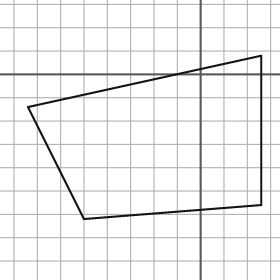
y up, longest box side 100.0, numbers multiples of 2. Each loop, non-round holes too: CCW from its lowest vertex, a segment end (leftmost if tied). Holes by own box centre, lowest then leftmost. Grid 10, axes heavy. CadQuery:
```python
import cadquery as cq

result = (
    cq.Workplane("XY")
    .moveTo(-50.0, -62.0)
    .lineTo(26.0, -56.0)
    .lineTo(26.0, 8.0)
    .lineTo(-74.0, -14.0)
    .close()
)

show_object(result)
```